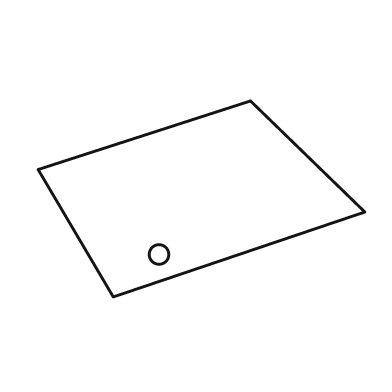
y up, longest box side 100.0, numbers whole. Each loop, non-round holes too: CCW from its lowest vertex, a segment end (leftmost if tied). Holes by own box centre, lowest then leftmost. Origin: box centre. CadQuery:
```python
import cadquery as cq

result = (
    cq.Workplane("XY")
    .moveTo(-27.0, -30.0)
    .lineTo(50.0, -4.0)
    .lineTo(15.0, 30.0)
    .lineTo(-50.0, 9.0)
    .close()
    .moveTo(-13.0, -17.0)
    .circle(3.0)
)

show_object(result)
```